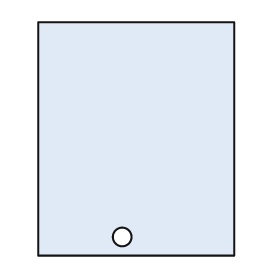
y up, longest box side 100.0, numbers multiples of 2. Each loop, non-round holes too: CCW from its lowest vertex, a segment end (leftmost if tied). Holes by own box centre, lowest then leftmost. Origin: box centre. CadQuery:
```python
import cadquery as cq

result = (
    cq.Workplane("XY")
    .moveTo(-42.0, -50.0)
    .lineTo(42.0, -50.0)
    .lineTo(42.0, 50.0)
    .lineTo(-42.0, 50.0)
    .close()
    .moveTo(-6.0, -42.0)
    .circle(4.0)
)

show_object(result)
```